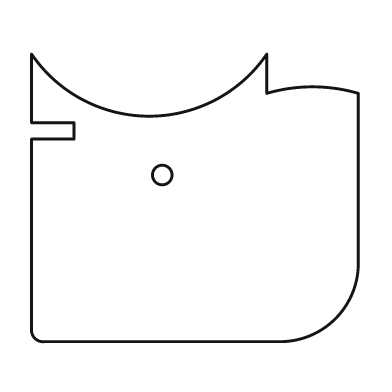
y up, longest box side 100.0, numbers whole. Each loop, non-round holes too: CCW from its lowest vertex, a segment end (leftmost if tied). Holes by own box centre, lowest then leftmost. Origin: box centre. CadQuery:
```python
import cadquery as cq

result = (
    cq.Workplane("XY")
    .moveTo(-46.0, -44.0)
    .lineTo(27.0, -44.0)
    .threePointArc((43.0, -37.0), (50.0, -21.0))
    .lineTo(50.0, 32.0)
    .threePointArc((36.0, 34.0), (22.0, 32.0))
    .lineTo(22.0, 44.0)
    .threePointArc((-14.0, 25.0), (-50.0, 44.0))
    .lineTo(-50.0, 23.0)
    .lineTo(-37.0, 23.0)
    .lineTo(-37.0, 18.0)
    .lineTo(-50.0, 18.0)
    .lineTo(-50.0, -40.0)
    .threePointArc((-49.0, -43.0), (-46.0, -44.0))
    .close()
    .moveTo(-10.0, 7.0)
    .circle(3.0)
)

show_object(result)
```